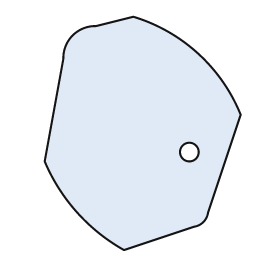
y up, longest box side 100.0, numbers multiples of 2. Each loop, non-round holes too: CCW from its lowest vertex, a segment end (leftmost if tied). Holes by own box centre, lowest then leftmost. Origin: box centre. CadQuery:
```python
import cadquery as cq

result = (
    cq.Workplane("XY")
    .moveTo(-8.0, -50.0)
    .lineTo(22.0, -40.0)
    .threePointArc((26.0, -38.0), (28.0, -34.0))
    .lineTo(42.0, 8.0)
    .threePointArc((24.0, 34.0), (-4.0, 50.0))
    .lineTo(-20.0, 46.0)
    .threePointArc((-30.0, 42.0), (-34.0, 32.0))
    .lineTo(-42.0, -12.0)
    .threePointArc((-28.0, -34.0), (-8.0, -50.0))
    .close()
    .moveTo(20.0, -8.0)
    .circle(4.0)
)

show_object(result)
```